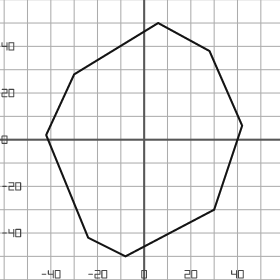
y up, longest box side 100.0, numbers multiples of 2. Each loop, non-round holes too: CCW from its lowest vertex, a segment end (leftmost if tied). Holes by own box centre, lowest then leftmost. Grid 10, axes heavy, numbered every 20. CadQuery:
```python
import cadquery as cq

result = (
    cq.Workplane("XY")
    .moveTo(-8.0, -50.0)
    .lineTo(30.0, -30.0)
    .lineTo(42.0, 6.0)
    .lineTo(28.0, 38.0)
    .lineTo(6.0, 50.0)
    .lineTo(-30.0, 28.0)
    .lineTo(-42.0, 2.0)
    .lineTo(-24.0, -42.0)
    .close()
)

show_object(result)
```